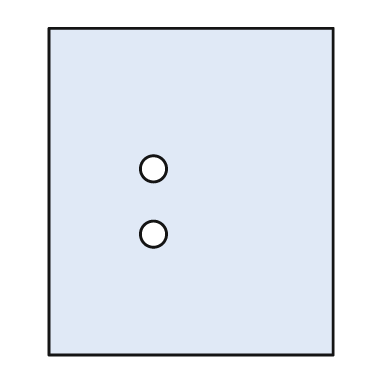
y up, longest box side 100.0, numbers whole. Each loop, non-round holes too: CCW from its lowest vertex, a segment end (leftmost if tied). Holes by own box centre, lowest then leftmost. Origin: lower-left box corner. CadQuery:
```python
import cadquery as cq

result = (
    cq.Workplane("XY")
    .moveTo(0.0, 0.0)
    .lineTo(87.0, 0.0)
    .lineTo(87.0, 100.0)
    .lineTo(0.0, 100.0)
    .close()
    .moveTo(32.0, 37.0)
    .circle(4.0)
    .moveTo(32.0, 57.0)
    .circle(4.0)
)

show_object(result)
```